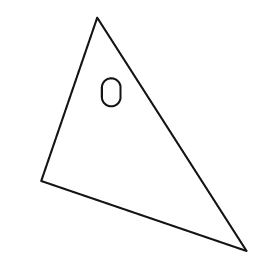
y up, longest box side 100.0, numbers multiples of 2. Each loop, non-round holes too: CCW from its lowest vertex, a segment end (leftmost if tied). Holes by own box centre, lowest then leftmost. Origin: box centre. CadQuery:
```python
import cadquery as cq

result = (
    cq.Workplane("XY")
    .moveTo(44.0, -50.0)
    .lineTo(-20.0, 50.0)
    .lineTo(-44.0, -20.0)
    .close()
    .moveTo(-18.0, 16.0)
    .threePointArc((-14.0, 12.0), (-10.0, 16.0))
    .lineTo(-10.0, 20.0)
    .threePointArc((-14.0, 24.0), (-18.0, 20.0))
    .close()
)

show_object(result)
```